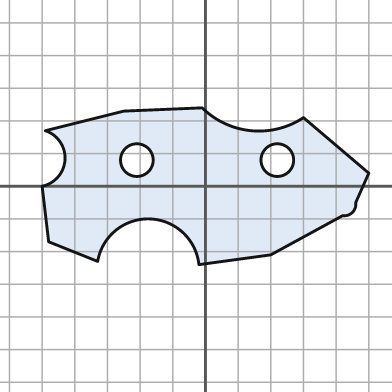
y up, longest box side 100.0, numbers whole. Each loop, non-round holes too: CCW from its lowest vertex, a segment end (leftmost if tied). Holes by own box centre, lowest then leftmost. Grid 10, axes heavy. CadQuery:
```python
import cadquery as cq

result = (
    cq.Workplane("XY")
    .moveTo(-2.0, -24.0)
    .lineTo(20.0, -21.0)
    .lineTo(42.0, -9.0)
    .threePointArc((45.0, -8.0), (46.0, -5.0))
    .lineTo(50.0, 4.0)
    .lineTo(30.0, 21.0)
    .threePointArc((14.0, 17.0), (-1.0, 24.0))
    .lineTo(-25.0, 23.0)
    .lineTo(-49.0, 17.0)
    .threePointArc((-43.0, 8.0), (-50.0, 0.0))
    .lineTo(-48.0, -17.0)
    .lineTo(-33.0, -23.0)
    .threePointArc((-17.0, -10.0), (-2.0, -24.0))
    .close()
    .moveTo(-21.0, 8.0)
    .circle(5.0)
    .moveTo(22.0, 8.0)
    .circle(5.0)
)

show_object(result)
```